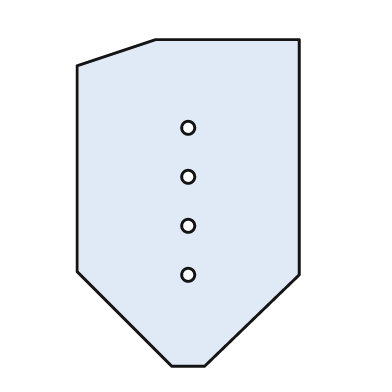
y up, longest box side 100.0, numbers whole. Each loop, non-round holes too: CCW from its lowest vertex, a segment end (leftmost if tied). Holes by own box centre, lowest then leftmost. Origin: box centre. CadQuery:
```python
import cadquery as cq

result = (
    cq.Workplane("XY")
    .moveTo(-5.0, -50.0)
    .lineTo(5.0, -50.0)
    .lineTo(34.0, -22.0)
    .lineTo(34.0, 50.0)
    .lineTo(-10.0, 50.0)
    .lineTo(-34.0, 42.0)
    .lineTo(-34.0, -21.0)
    .close()
    .moveTo(0.0, -22.0)
    .circle(2.0)
    .moveTo(0.0, -7.0)
    .circle(2.0)
    .moveTo(0.0, 8.0)
    .circle(2.0)
    .moveTo(0.0, 23.0)
    .circle(2.0)
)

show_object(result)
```